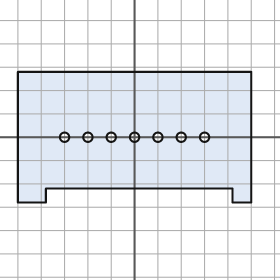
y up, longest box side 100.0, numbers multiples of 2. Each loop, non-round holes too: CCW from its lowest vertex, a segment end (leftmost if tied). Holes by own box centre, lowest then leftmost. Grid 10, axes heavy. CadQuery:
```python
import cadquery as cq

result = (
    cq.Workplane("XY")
    .moveTo(-50.0, -28.0)
    .lineTo(-38.0, -28.0)
    .lineTo(-38.0, -22.0)
    .lineTo(42.0, -22.0)
    .lineTo(42.0, -28.0)
    .lineTo(50.0, -28.0)
    .lineTo(50.0, 28.0)
    .lineTo(-50.0, 28.0)
    .close()
    .moveTo(-30.0, 0.0)
    .circle(2.0)
    .moveTo(-20.0, 0.0)
    .circle(2.0)
    .moveTo(-10.0, 0.0)
    .circle(2.0)
    .moveTo(0.0, 0.0)
    .circle(2.0)
    .moveTo(10.0, 0.0)
    .circle(2.0)
    .moveTo(20.0, 0.0)
    .circle(2.0)
    .moveTo(30.0, 0.0)
    .circle(2.0)
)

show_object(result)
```